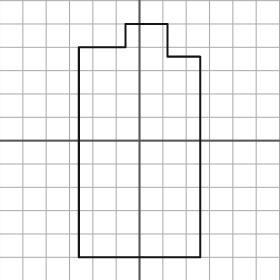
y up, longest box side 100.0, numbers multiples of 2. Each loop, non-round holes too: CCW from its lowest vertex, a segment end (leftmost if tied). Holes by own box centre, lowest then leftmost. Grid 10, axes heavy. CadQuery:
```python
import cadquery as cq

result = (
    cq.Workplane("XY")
    .moveTo(-26.0, -50.0)
    .lineTo(26.0, -50.0)
    .lineTo(26.0, 36.0)
    .lineTo(12.0, 36.0)
    .lineTo(12.0, 50.0)
    .lineTo(-6.0, 50.0)
    .lineTo(-6.0, 40.0)
    .lineTo(-26.0, 40.0)
    .close()
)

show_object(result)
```